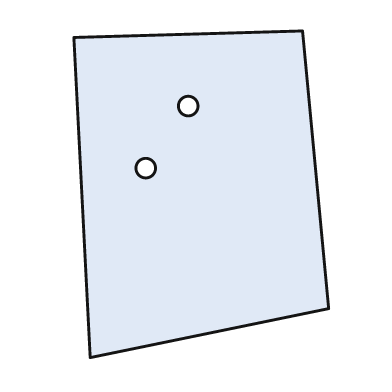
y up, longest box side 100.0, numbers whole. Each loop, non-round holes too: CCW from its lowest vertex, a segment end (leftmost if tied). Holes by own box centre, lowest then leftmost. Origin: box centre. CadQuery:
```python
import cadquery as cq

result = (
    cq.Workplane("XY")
    .moveTo(-34.0, -50.0)
    .lineTo(39.0, -35.0)
    .lineTo(31.0, 50.0)
    .lineTo(-39.0, 48.0)
    .close()
    .moveTo(-17.0, 8.0)
    .circle(3.0)
    .moveTo(-4.0, 27.0)
    .circle(3.0)
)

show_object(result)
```